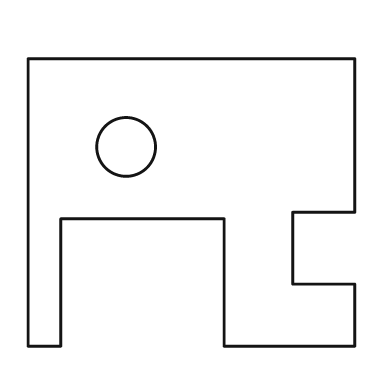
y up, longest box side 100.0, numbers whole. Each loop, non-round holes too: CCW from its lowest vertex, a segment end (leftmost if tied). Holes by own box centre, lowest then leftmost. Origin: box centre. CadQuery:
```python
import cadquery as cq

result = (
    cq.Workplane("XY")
    .moveTo(-50.0, -44.0)
    .lineTo(-40.0, -44.0)
    .lineTo(-40.0, -5.0)
    .lineTo(10.0, -5.0)
    .lineTo(10.0, -44.0)
    .lineTo(50.0, -44.0)
    .lineTo(50.0, -25.0)
    .lineTo(31.0, -25.0)
    .lineTo(31.0, -3.0)
    .lineTo(50.0, -3.0)
    .lineTo(50.0, 44.0)
    .lineTo(-50.0, 44.0)
    .close()
    .moveTo(-20.0, 17.0)
    .circle(9.0)
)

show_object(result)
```